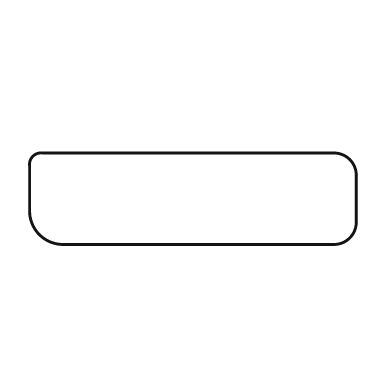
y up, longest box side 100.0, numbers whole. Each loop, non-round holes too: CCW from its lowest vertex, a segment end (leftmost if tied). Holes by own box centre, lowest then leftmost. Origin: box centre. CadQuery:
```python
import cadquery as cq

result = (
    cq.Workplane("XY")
    .moveTo(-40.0, -14.0)
    .lineTo(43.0, -14.0)
    .threePointArc((48.0, -12.0), (50.0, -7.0))
    .lineTo(50.0, 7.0)
    .threePointArc((48.0, 12.0), (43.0, 14.0))
    .lineTo(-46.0, 14.0)
    .threePointArc((-49.0, 13.0), (-50.0, 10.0))
    .lineTo(-50.0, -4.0)
    .threePointArc((-47.0, -11.0), (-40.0, -14.0))
    .close()
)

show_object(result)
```